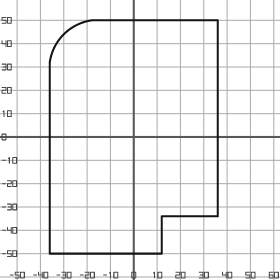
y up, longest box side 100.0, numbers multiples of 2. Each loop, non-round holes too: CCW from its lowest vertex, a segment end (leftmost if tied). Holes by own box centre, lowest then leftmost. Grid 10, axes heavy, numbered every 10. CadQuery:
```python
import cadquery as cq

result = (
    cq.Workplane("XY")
    .moveTo(-36.0, -50.0)
    .lineTo(12.0, -50.0)
    .lineTo(12.0, -34.0)
    .lineTo(36.0, -34.0)
    .lineTo(36.0, 50.0)
    .lineTo(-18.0, 50.0)
    .threePointArc((-30.0, 44.0), (-36.0, 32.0))
    .close()
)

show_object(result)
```